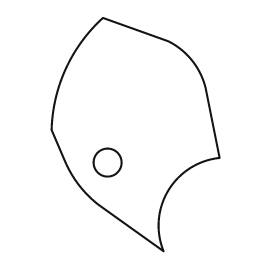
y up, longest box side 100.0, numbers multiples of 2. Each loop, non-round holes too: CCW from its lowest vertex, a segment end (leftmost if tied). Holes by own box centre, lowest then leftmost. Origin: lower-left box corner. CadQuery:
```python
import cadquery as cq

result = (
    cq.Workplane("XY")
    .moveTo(48.0, 0.0)
    .threePointArc((50.0, 26.0), (72.0, 40.0))
    .lineTo(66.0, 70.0)
    .threePointArc((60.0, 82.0), (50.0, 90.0))
    .lineTo(22.0, 100.0)
    .threePointArc((6.0, 78.0), (0.0, 52.0))
    .lineTo(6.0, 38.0)
    .threePointArc((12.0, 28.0), (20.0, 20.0))
    .close()
    .moveTo(24.0, 38.0)
    .circle(6.0)
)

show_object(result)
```